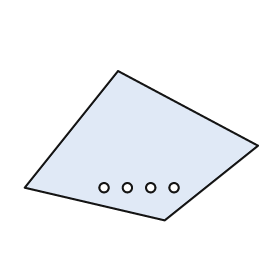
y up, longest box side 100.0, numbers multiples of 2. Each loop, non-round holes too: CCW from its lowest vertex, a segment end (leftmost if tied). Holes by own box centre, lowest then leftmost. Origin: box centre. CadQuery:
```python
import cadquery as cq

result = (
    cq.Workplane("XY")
    .moveTo(10.0, -32.0)
    .lineTo(50.0, 0.0)
    .lineTo(-10.0, 32.0)
    .lineTo(-50.0, -18.0)
    .close()
    .moveTo(-16.0, -18.0)
    .circle(2.0)
    .moveTo(-6.0, -18.0)
    .circle(2.0)
    .moveTo(4.0, -18.0)
    .circle(2.0)
    .moveTo(14.0, -18.0)
    .circle(2.0)
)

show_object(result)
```